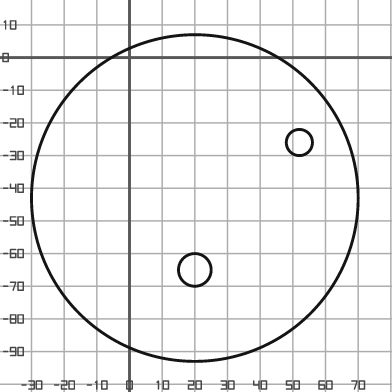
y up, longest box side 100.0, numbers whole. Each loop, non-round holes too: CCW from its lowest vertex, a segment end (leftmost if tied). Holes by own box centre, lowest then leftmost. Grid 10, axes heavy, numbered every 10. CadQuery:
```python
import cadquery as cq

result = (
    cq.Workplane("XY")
    .moveTo(20.0, -43.0)
    .circle(50.0)
    .moveTo(20.0, -65.0)
    .circle(5.0)
    .moveTo(52.0, -26.0)
    .circle(4.0)
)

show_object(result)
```